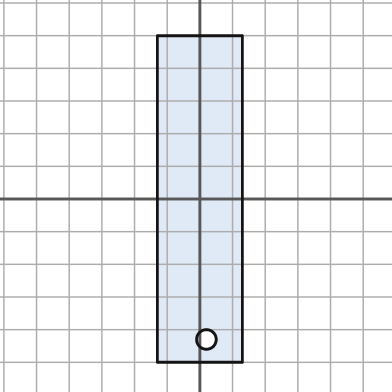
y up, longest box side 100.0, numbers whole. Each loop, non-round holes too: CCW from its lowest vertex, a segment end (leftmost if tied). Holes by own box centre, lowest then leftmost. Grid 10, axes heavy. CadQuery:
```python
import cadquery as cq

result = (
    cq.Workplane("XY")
    .moveTo(-13.0, -50.0)
    .lineTo(13.0, -50.0)
    .lineTo(13.0, 50.0)
    .lineTo(-13.0, 50.0)
    .close()
    .moveTo(2.0, -43.0)
    .circle(3.0)
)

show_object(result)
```